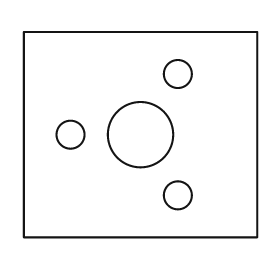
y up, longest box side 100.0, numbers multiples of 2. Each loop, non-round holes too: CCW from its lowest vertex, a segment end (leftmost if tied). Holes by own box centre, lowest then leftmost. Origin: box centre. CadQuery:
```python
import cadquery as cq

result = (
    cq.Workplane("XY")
    .moveTo(-50.0, -44.0)
    .lineTo(50.0, -44.0)
    .lineTo(50.0, 44.0)
    .lineTo(-50.0, 44.0)
    .close()
    .moveTo(16.0, -26.0)
    .circle(6.0)
    .moveTo(-30.0, 0.0)
    .circle(6.0)
    .moveTo(0.0, 0.0)
    .circle(14.0)
    .moveTo(16.0, 26.0)
    .circle(6.0)
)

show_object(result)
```